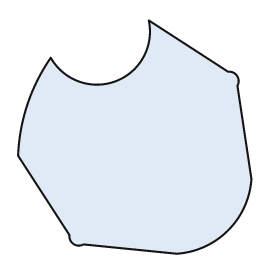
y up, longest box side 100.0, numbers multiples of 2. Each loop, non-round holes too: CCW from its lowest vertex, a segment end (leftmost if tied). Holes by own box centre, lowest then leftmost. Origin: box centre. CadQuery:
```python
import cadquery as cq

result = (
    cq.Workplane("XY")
    .moveTo(18.0, -50.0)
    .threePointArc((40.0, -40.0), (50.0, -18.0))
    .lineTo(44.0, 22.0)
    .threePointArc((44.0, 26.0), (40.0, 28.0))
    .lineTo(6.0, 50.0)
    .threePointArc((-8.0, 24.0), (-36.0, 34.0))
    .threePointArc((-46.0, 14.0), (-50.0, -8.0))
    .lineTo(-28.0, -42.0)
    .threePointArc((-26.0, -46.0), (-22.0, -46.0))
    .close()
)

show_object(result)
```